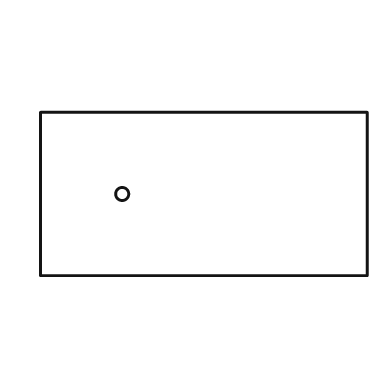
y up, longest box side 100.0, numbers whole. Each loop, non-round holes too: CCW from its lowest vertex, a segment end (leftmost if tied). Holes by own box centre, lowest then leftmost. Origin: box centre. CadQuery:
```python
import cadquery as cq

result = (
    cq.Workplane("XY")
    .moveTo(-50.0, -25.0)
    .lineTo(50.0, -25.0)
    .lineTo(50.0, 25.0)
    .lineTo(-50.0, 25.0)
    .close()
    .moveTo(-25.0, 0.0)
    .circle(2.0)
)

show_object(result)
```